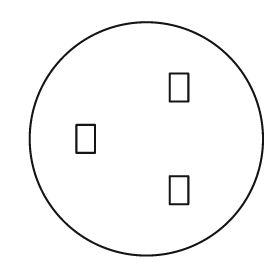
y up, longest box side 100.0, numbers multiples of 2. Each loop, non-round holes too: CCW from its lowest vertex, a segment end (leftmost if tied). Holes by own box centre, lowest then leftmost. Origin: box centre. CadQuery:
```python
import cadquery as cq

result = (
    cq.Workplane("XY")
    .moveTo(0.0, 0.0)
    .circle(50.0)
    .moveTo(10.0, -28.0)
    .lineTo(18.0, -28.0)
    .lineTo(18.0, -16.0)
    .lineTo(10.0, -16.0)
    .close()
    .moveTo(-30.0, -6.0)
    .lineTo(-22.0, -6.0)
    .lineTo(-22.0, 6.0)
    .lineTo(-30.0, 6.0)
    .close()
    .moveTo(10.0, 16.0)
    .lineTo(18.0, 16.0)
    .lineTo(18.0, 28.0)
    .lineTo(10.0, 28.0)
    .close()
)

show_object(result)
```